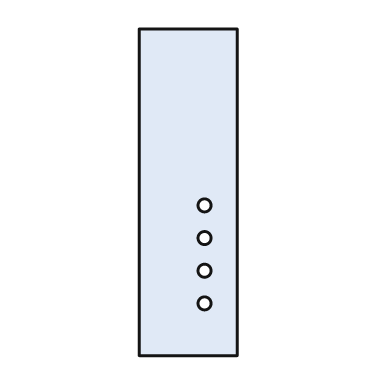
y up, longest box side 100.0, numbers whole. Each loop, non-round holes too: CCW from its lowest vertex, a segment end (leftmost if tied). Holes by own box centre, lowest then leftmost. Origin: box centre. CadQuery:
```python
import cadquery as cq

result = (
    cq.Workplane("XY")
    .moveTo(-15.0, -50.0)
    .lineTo(15.0, -50.0)
    .lineTo(15.0, 50.0)
    .lineTo(-15.0, 50.0)
    .close()
    .moveTo(5.0, -34.0)
    .circle(2.0)
    .moveTo(5.0, -24.0)
    .circle(2.0)
    .moveTo(5.0, -14.0)
    .circle(2.0)
    .moveTo(5.0, -4.0)
    .circle(2.0)
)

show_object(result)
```